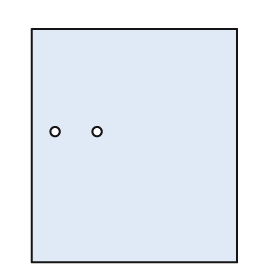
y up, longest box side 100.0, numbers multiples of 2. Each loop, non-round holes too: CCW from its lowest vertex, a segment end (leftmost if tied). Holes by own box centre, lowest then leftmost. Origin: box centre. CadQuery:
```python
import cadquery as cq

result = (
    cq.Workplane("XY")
    .moveTo(-44.0, -50.0)
    .lineTo(44.0, -50.0)
    .lineTo(44.0, 50.0)
    .lineTo(-44.0, 50.0)
    .close()
    .moveTo(-34.0, 6.0)
    .circle(2.0)
    .moveTo(-16.0, 6.0)
    .circle(2.0)
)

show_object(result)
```